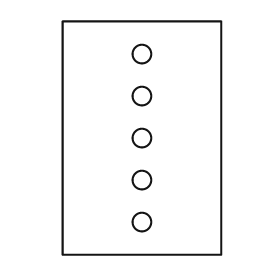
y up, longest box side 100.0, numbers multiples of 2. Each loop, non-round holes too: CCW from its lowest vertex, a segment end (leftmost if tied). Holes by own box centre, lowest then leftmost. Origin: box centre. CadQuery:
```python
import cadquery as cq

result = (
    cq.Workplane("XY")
    .moveTo(-34.0, -50.0)
    .lineTo(34.0, -50.0)
    .lineTo(34.0, 50.0)
    .lineTo(-34.0, 50.0)
    .close()
    .moveTo(0.0, -36.0)
    .circle(4.0)
    .moveTo(0.0, -18.0)
    .circle(4.0)
    .moveTo(0.0, 0.0)
    .circle(4.0)
    .moveTo(0.0, 18.0)
    .circle(4.0)
    .moveTo(0.0, 36.0)
    .circle(4.0)
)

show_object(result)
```